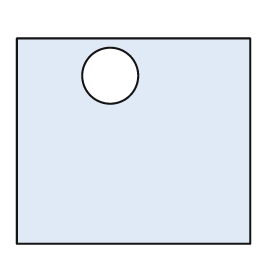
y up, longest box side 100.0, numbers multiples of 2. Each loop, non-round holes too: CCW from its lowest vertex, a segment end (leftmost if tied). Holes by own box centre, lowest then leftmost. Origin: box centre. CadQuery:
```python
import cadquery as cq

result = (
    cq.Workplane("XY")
    .moveTo(-50.0, -44.0)
    .lineTo(50.0, -44.0)
    .lineTo(50.0, 44.0)
    .lineTo(-50.0, 44.0)
    .close()
    .moveTo(-10.0, 28.0)
    .circle(12.0)
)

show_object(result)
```